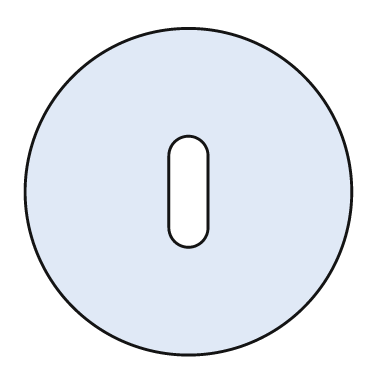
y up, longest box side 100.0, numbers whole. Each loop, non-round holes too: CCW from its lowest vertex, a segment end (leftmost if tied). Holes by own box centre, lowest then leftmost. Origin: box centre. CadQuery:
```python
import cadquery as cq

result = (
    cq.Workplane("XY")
    .moveTo(0.0, 0.0)
    .circle(50.0)
    .moveTo(-6.0, -11.0)
    .threePointArc((0.0, -17.0), (6.0, -11.0))
    .lineTo(6.0, 11.0)
    .threePointArc((0.0, 17.0), (-6.0, 11.0))
    .close()
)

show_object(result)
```